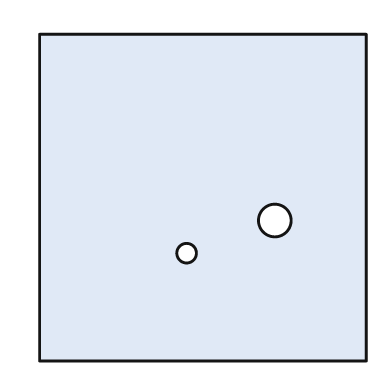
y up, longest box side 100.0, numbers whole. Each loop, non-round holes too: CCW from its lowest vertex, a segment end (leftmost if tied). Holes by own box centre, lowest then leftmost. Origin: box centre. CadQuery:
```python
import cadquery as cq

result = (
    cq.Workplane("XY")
    .moveTo(-50.0, -50.0)
    .lineTo(50.0, -50.0)
    .lineTo(50.0, 50.0)
    .lineTo(-50.0, 50.0)
    .close()
    .moveTo(-5.0, -17.0)
    .circle(3.0)
    .moveTo(22.0, -7.0)
    .circle(5.0)
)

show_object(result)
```